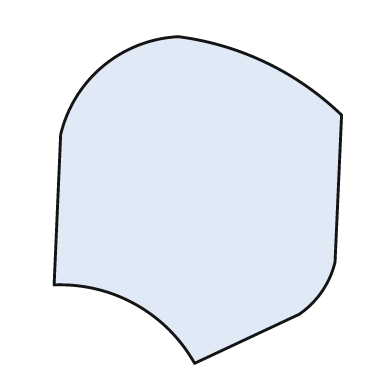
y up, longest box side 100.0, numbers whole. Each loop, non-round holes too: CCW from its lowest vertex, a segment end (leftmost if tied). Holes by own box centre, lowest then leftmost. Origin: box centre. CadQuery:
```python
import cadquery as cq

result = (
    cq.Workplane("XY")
    .moveTo(-1.0, -50.0)
    .lineTo(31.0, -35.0)
    .threePointArc((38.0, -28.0), (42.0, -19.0))
    .lineTo(44.0, 26.0)
    .threePointArc((21.0, 42.0), (-6.0, 50.0))
    .threePointArc((-29.0, 41.0), (-42.0, 20.0))
    .lineTo(-44.0, -26.0)
    .threePointArc((-19.0, -32.0), (-1.0, -50.0))
    .close()
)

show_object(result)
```